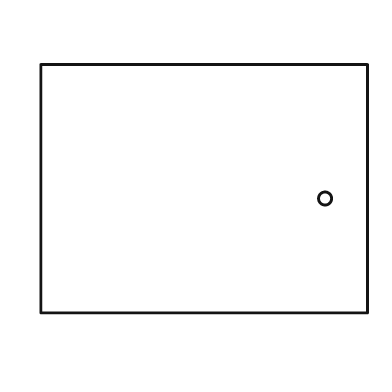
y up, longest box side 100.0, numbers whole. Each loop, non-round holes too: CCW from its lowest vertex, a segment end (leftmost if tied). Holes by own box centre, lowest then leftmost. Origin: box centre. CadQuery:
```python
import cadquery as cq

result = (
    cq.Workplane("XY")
    .moveTo(-50.0, -38.0)
    .lineTo(50.0, -38.0)
    .lineTo(50.0, 38.0)
    .lineTo(-50.0, 38.0)
    .close()
    .moveTo(37.0, -3.0)
    .circle(2.0)
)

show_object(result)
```